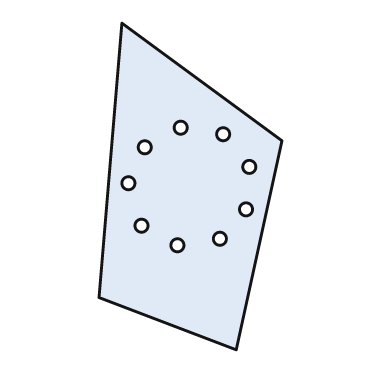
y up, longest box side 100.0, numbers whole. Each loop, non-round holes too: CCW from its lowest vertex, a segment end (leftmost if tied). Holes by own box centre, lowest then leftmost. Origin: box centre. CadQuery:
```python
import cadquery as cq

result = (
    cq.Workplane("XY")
    .moveTo(14.0, -50.0)
    .lineTo(28.0, 14.0)
    .lineTo(-21.0, 50.0)
    .lineTo(-28.0, -34.0)
    .close()
    .moveTo(-4.0, -18.0)
    .circle(2.0)
    .moveTo(9.0, -16.0)
    .circle(2.0)
    .moveTo(-15.0, -12.0)
    .circle(2.0)
    .moveTo(17.0, -7.0)
    .circle(2.0)
    .moveTo(-19.0, 1.0)
    .circle(2.0)
    .moveTo(18.0, 6.0)
    .circle(2.0)
    .moveTo(-14.0, 12.0)
    .circle(2.0)
    .moveTo(10.0, 16.0)
    .circle(2.0)
    .moveTo(-3.0, 18.0)
    .circle(2.0)
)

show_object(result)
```